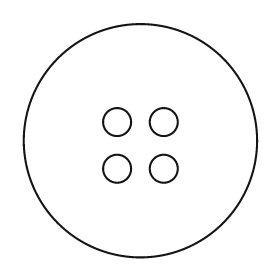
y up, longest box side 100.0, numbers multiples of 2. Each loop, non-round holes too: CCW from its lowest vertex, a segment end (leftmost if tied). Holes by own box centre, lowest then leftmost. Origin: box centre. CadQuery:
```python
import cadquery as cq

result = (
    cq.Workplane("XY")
    .moveTo(0.0, 0.0)
    .circle(50.0)
    .moveTo(-10.0, -12.0)
    .circle(6.0)
    .moveTo(10.0, -12.0)
    .circle(6.0)
    .moveTo(-10.0, 8.0)
    .circle(6.0)
    .moveTo(10.0, 8.0)
    .circle(6.0)
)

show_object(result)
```